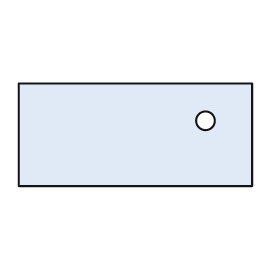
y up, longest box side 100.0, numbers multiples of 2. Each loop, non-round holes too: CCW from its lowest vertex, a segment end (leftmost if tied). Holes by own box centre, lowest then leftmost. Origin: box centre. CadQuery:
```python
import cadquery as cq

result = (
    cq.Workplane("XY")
    .moveTo(-50.0, -22.0)
    .lineTo(50.0, -22.0)
    .lineTo(50.0, 22.0)
    .lineTo(-50.0, 22.0)
    .close()
    .moveTo(30.0, 6.0)
    .circle(4.0)
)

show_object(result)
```